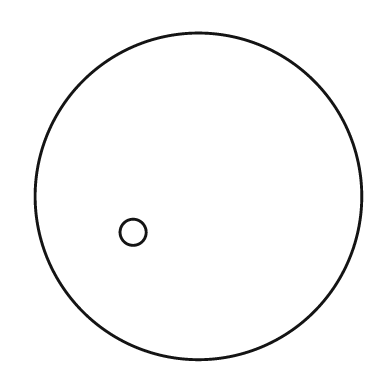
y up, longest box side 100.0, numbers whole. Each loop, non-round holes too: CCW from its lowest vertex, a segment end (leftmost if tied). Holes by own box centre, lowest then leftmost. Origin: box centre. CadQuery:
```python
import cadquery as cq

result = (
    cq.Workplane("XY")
    .moveTo(0.0, 0.0)
    .circle(50.0)
    .moveTo(-20.0, -11.0)
    .circle(4.0)
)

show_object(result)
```